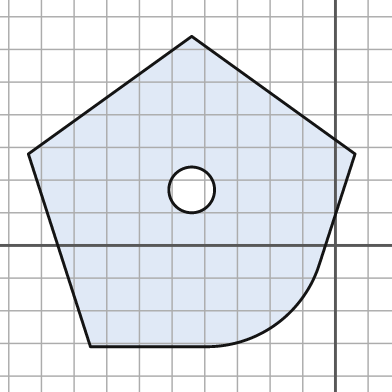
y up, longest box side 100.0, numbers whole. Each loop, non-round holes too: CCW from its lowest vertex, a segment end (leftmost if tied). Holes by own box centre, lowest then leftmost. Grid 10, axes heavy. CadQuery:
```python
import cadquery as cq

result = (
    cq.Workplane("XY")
    .moveTo(-75.0, -31.0)
    .lineTo(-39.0, -31.0)
    .threePointArc((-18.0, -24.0), (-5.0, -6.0))
    .lineTo(6.0, 28.0)
    .lineTo(-44.0, 64.0)
    .lineTo(-94.0, 28.0)
    .close()
    .moveTo(-44.0, 17.0)
    .circle(7.0)
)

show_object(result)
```